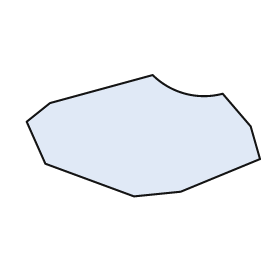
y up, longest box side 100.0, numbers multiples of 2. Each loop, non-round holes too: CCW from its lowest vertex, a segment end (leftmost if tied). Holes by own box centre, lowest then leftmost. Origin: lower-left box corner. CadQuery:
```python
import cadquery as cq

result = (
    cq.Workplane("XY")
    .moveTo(46.0, 0.0)
    .lineTo(66.0, 2.0)
    .lineTo(100.0, 16.0)
    .lineTo(96.0, 30.0)
    .lineTo(84.0, 44.0)
    .threePointArc((68.0, 44.0), (54.0, 52.0))
    .lineTo(10.0, 40.0)
    .lineTo(0.0, 32.0)
    .lineTo(8.0, 14.0)
    .close()
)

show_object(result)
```